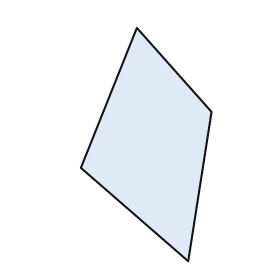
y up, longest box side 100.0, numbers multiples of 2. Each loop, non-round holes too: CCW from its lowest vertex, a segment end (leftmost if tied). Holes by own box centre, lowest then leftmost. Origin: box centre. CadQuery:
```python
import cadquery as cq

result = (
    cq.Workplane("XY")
    .moveTo(18.0, -50.0)
    .lineTo(28.0, 14.0)
    .lineTo(-4.0, 50.0)
    .lineTo(-28.0, -10.0)
    .close()
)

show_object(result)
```